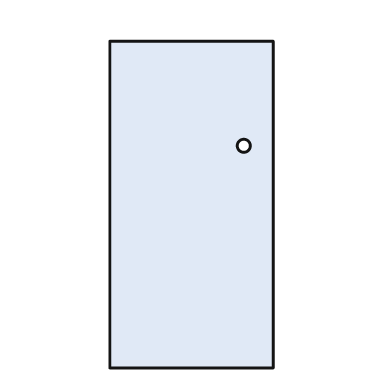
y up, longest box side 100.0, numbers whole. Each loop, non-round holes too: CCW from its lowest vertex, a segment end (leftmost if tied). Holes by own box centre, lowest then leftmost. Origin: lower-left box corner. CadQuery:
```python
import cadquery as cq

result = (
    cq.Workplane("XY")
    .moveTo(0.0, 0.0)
    .lineTo(50.0, 0.0)
    .lineTo(50.0, 100.0)
    .lineTo(0.0, 100.0)
    .close()
    .moveTo(41.0, 68.0)
    .circle(2.0)
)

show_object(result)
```